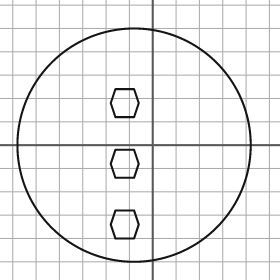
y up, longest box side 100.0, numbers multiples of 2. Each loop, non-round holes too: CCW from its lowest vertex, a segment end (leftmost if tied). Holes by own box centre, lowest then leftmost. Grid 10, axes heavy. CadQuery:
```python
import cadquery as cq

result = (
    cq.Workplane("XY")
    .moveTo(-8.0, 0.0)
    .circle(50.0)
    .moveTo(-16.0, -40.0)
    .lineTo(-8.0, -40.0)
    .lineTo(-6.0, -34.0)
    .lineTo(-8.0, -28.0)
    .lineTo(-16.0, -28.0)
    .lineTo(-18.0, -34.0)
    .close()
    .moveTo(-16.0, -14.0)
    .lineTo(-8.0, -14.0)
    .lineTo(-6.0, -8.0)
    .lineTo(-8.0, -2.0)
    .lineTo(-16.0, -2.0)
    .lineTo(-18.0, -8.0)
    .close()
    .moveTo(-16.0, 12.0)
    .lineTo(-8.0, 12.0)
    .lineTo(-6.0, 18.0)
    .lineTo(-8.0, 24.0)
    .lineTo(-16.0, 24.0)
    .lineTo(-18.0, 18.0)
    .close()
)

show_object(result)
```